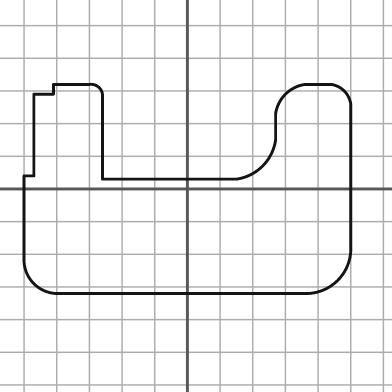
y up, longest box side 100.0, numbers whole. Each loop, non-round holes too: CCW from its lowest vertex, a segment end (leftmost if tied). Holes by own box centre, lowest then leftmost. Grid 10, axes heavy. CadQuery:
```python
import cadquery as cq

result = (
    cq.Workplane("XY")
    .moveTo(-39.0, -32.0)
    .lineTo(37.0, -32.0)
    .threePointArc((46.0, -28.0), (50.0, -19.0))
    .lineTo(50.0, 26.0)
    .threePointArc((48.0, 30.0), (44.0, 32.0))
    .lineTo(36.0, 32.0)
    .threePointArc((30.0, 29.0), (27.0, 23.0))
    .lineTo(27.0, 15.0)
    .threePointArc((23.0, 7.0), (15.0, 3.0))
    .lineTo(-26.0, 3.0)
    .lineTo(-26.0, 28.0)
    .threePointArc((-27.0, 31.0), (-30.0, 32.0))
    .lineTo(-41.0, 32.0)
    .lineTo(-41.0, 29.0)
    .lineTo(-47.0, 29.0)
    .lineTo(-47.0, 4.0)
    .lineTo(-50.0, 4.0)
    .lineTo(-50.0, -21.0)
    .threePointArc((-47.0, -29.0), (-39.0, -32.0))
    .close()
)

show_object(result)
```